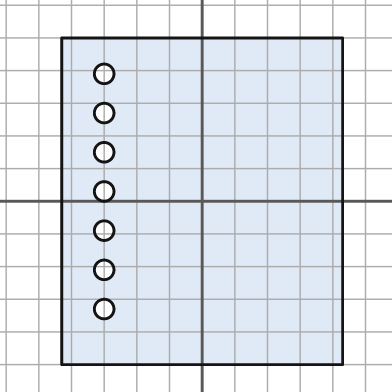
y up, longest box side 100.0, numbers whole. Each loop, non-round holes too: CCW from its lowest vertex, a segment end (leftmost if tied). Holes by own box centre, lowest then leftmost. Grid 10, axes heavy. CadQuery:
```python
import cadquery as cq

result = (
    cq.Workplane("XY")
    .moveTo(-43.0, -50.0)
    .lineTo(43.0, -50.0)
    .lineTo(43.0, 50.0)
    .lineTo(-43.0, 50.0)
    .close()
    .moveTo(-30.0, -33.0)
    .circle(3.0)
    .moveTo(-30.0, -21.0)
    .circle(3.0)
    .moveTo(-30.0, -9.0)
    .circle(3.0)
    .moveTo(-30.0, 3.0)
    .circle(3.0)
    .moveTo(-30.0, 15.0)
    .circle(3.0)
    .moveTo(-30.0, 27.0)
    .circle(3.0)
    .moveTo(-30.0, 39.0)
    .circle(3.0)
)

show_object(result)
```